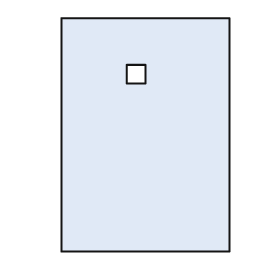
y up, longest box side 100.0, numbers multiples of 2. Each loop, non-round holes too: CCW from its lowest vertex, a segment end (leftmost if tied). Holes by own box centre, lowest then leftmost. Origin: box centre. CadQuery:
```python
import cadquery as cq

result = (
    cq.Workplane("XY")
    .moveTo(-36.0, -50.0)
    .lineTo(36.0, -50.0)
    .lineTo(36.0, 50.0)
    .lineTo(-36.0, 50.0)
    .close()
    .moveTo(-8.0, 22.0)
    .lineTo(0.0, 22.0)
    .lineTo(0.0, 30.0)
    .lineTo(-8.0, 30.0)
    .close()
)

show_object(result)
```